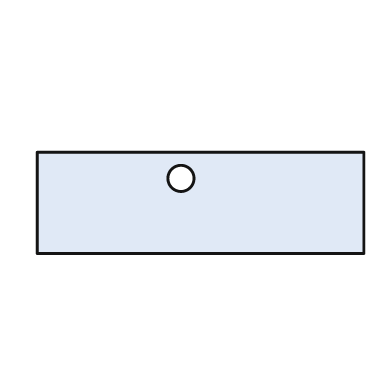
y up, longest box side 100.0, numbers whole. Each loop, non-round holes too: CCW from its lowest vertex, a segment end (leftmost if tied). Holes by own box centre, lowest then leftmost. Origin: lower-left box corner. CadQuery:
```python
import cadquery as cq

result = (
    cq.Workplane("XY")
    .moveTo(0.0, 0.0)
    .lineTo(100.0, 0.0)
    .lineTo(100.0, 31.0)
    .lineTo(0.0, 31.0)
    .close()
    .moveTo(44.0, 23.0)
    .circle(4.0)
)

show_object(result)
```